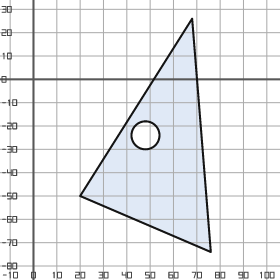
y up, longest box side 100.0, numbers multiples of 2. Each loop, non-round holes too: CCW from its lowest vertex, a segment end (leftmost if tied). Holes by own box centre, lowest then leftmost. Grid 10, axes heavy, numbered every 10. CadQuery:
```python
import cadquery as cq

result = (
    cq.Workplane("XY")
    .moveTo(76.0, -74.0)
    .lineTo(68.0, 26.0)
    .lineTo(20.0, -50.0)
    .close()
    .moveTo(48.0, -24.0)
    .circle(6.0)
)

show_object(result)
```